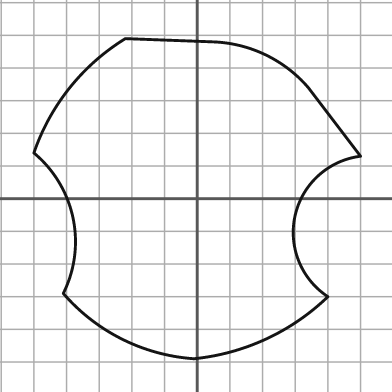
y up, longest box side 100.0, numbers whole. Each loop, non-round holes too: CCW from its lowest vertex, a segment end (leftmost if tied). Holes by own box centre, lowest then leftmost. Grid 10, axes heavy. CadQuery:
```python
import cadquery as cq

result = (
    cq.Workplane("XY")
    .moveTo(-1.0, -49.0)
    .threePointArc((21.0, -43.0), (40.0, -30.0))
    .threePointArc((30.0, -5.0), (50.0, 13.0))
    .lineTo(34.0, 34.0)
    .threePointArc((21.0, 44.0), (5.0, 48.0))
    .lineTo(-22.0, 49.0)
    .threePointArc((-39.0, 34.0), (-50.0, 14.0))
    .threePointArc((-38.0, -6.0), (-41.0, -29.0))
    .threePointArc((-23.0, -43.0), (-1.0, -49.0))
    .close()
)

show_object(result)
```